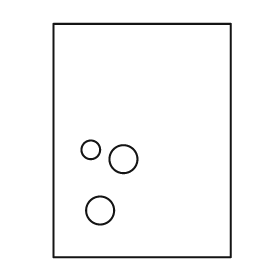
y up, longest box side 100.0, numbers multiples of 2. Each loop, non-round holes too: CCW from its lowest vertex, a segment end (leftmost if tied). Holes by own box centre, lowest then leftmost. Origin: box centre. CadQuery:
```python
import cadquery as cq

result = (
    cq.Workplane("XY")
    .moveTo(-38.0, -50.0)
    .lineTo(38.0, -50.0)
    .lineTo(38.0, 50.0)
    .lineTo(-38.0, 50.0)
    .close()
    .moveTo(-18.0, -30.0)
    .circle(6.0)
    .moveTo(-8.0, -8.0)
    .circle(6.0)
    .moveTo(-22.0, -4.0)
    .circle(4.0)
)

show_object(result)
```